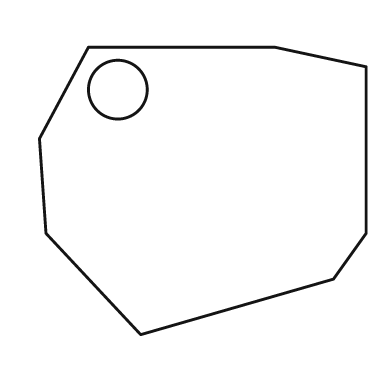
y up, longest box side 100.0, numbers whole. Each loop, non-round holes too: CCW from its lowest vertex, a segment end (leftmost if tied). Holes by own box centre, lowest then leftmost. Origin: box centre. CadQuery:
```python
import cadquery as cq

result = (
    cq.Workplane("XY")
    .moveTo(-19.0, -44.0)
    .lineTo(40.0, -27.0)
    .lineTo(50.0, -13.0)
    .lineTo(50.0, 38.0)
    .lineTo(22.0, 44.0)
    .lineTo(-35.0, 44.0)
    .lineTo(-50.0, 16.0)
    .lineTo(-48.0, -13.0)
    .close()
    .moveTo(-26.0, 31.0)
    .circle(9.0)
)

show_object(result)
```